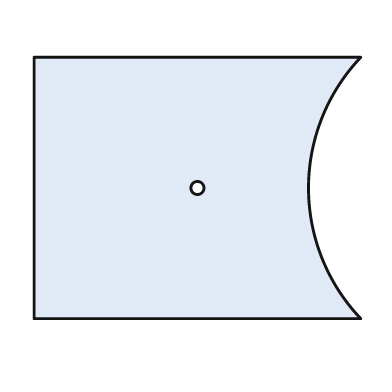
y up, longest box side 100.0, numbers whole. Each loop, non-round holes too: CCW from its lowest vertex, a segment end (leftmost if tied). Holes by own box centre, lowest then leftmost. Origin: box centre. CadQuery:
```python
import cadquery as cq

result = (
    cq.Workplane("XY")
    .moveTo(-50.0, -40.0)
    .lineTo(50.0, -40.0)
    .threePointArc((34.0, 0.0), (50.0, 40.0))
    .lineTo(-50.0, 40.0)
    .close()
    .moveTo(0.0, 0.0)
    .circle(2.0)
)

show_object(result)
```